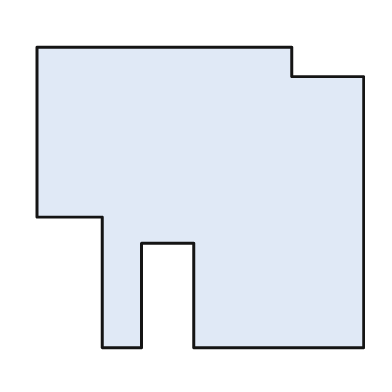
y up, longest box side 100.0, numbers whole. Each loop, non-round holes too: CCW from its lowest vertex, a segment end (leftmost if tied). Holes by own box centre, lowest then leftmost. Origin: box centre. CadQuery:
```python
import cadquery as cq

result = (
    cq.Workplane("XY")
    .moveTo(-30.0, -46.0)
    .lineTo(-18.0, -46.0)
    .lineTo(-18.0, -14.0)
    .lineTo(-2.0, -14.0)
    .lineTo(-2.0, -46.0)
    .lineTo(50.0, -46.0)
    .lineTo(50.0, 37.0)
    .lineTo(28.0, 37.0)
    .lineTo(28.0, 46.0)
    .lineTo(-50.0, 46.0)
    .lineTo(-50.0, -6.0)
    .lineTo(-30.0, -6.0)
    .close()
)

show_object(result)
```